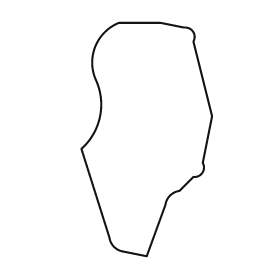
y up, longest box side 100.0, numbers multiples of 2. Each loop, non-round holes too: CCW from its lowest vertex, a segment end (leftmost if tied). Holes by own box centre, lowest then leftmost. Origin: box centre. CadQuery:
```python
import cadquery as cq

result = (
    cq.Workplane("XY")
    .moveTo(0.0, -50.0)
    .lineTo(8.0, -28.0)
    .threePointArc((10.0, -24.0), (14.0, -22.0))
    .lineTo(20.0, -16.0)
    .threePointArc((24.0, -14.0), (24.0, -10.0))
    .lineTo(28.0, 10.0)
    .lineTo(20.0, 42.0)
    .threePointArc((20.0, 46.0), (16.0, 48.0))
    .lineTo(6.0, 50.0)
    .lineTo(-12.0, 50.0)
    .threePointArc((-22.0, 40.0), (-22.0, 26.0))
    .threePointArc((-20.0, 10.0), (-28.0, -4.0))
    .lineTo(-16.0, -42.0)
    .threePointArc((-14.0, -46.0), (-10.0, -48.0))
    .close()
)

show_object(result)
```